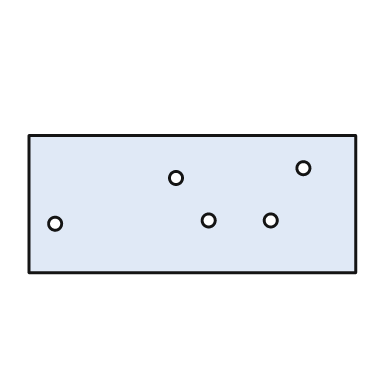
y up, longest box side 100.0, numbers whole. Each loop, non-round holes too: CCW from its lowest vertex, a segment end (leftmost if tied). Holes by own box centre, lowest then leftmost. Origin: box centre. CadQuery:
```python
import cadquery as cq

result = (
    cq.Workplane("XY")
    .moveTo(-50.0, -21.0)
    .lineTo(50.0, -21.0)
    .lineTo(50.0, 21.0)
    .lineTo(-50.0, 21.0)
    .close()
    .moveTo(-42.0, -6.0)
    .circle(2.0)
    .moveTo(5.0, -5.0)
    .circle(2.0)
    .moveTo(24.0, -5.0)
    .circle(2.0)
    .moveTo(-5.0, 8.0)
    .circle(2.0)
    .moveTo(34.0, 11.0)
    .circle(2.0)
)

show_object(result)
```